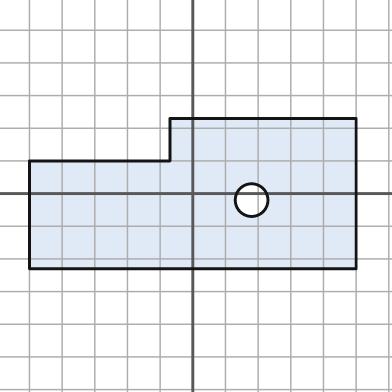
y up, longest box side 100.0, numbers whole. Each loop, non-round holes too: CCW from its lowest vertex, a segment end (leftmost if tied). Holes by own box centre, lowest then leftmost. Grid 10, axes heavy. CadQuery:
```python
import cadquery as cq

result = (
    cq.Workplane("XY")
    .moveTo(-50.0, -23.0)
    .lineTo(50.0, -23.0)
    .lineTo(50.0, 23.0)
    .lineTo(-7.0, 23.0)
    .lineTo(-7.0, 10.0)
    .lineTo(-50.0, 10.0)
    .close()
    .moveTo(18.0, -2.0)
    .circle(5.0)
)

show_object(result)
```